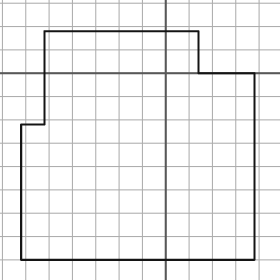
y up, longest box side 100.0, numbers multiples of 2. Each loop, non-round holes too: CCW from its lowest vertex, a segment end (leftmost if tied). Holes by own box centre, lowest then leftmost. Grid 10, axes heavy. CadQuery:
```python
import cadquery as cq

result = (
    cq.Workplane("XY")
    .moveTo(-62.0, -80.0)
    .lineTo(38.0, -80.0)
    .lineTo(38.0, 0.0)
    .lineTo(14.0, 0.0)
    .lineTo(14.0, 18.0)
    .lineTo(-52.0, 18.0)
    .lineTo(-52.0, -22.0)
    .lineTo(-62.0, -22.0)
    .close()
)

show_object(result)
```